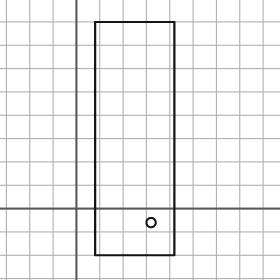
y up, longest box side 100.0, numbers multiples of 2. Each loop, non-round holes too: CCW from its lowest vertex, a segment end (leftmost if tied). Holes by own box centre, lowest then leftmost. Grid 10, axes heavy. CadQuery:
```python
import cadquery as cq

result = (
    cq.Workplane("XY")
    .moveTo(8.0, -20.0)
    .lineTo(42.0, -20.0)
    .lineTo(42.0, 80.0)
    .lineTo(8.0, 80.0)
    .close()
    .moveTo(32.0, -6.0)
    .circle(2.0)
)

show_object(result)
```